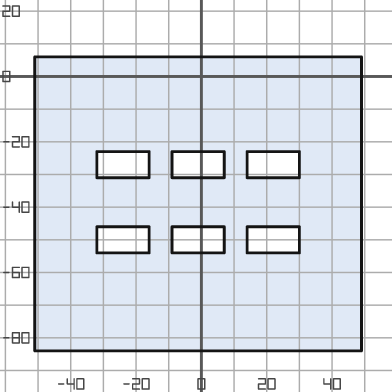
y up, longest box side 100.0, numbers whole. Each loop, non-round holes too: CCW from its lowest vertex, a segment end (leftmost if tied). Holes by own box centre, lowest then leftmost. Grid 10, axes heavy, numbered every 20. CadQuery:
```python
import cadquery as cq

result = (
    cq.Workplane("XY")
    .moveTo(-51.0, -84.0)
    .lineTo(49.0, -84.0)
    .lineTo(49.0, 6.0)
    .lineTo(-51.0, 6.0)
    .close()
    .moveTo(-32.0, -54.0)
    .lineTo(-16.0, -54.0)
    .lineTo(-16.0, -46.0)
    .lineTo(-32.0, -46.0)
    .close()
    .moveTo(-9.0, -54.0)
    .lineTo(7.0, -54.0)
    .lineTo(7.0, -46.0)
    .lineTo(-9.0, -46.0)
    .close()
    .moveTo(14.0, -54.0)
    .lineTo(30.0, -54.0)
    .lineTo(30.0, -46.0)
    .lineTo(14.0, -46.0)
    .close()
    .moveTo(-32.0, -31.0)
    .lineTo(-16.0, -31.0)
    .lineTo(-16.0, -23.0)
    .lineTo(-32.0, -23.0)
    .close()
    .moveTo(-9.0, -31.0)
    .lineTo(7.0, -31.0)
    .lineTo(7.0, -23.0)
    .lineTo(-9.0, -23.0)
    .close()
    .moveTo(14.0, -31.0)
    .lineTo(30.0, -31.0)
    .lineTo(30.0, -23.0)
    .lineTo(14.0, -23.0)
    .close()
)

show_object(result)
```